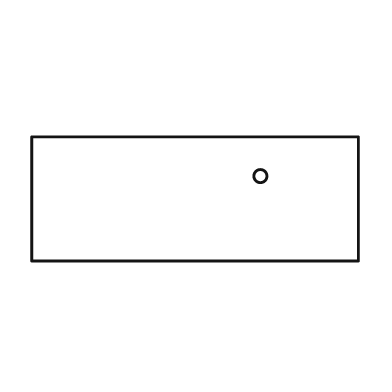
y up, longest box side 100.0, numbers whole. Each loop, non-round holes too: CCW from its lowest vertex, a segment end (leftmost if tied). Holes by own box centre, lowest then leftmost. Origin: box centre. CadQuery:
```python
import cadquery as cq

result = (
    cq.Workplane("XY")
    .moveTo(-50.0, -19.0)
    .lineTo(50.0, -19.0)
    .lineTo(50.0, 19.0)
    .lineTo(-50.0, 19.0)
    .close()
    .moveTo(20.0, 7.0)
    .circle(2.0)
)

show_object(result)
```